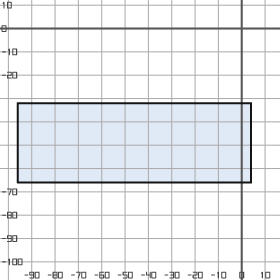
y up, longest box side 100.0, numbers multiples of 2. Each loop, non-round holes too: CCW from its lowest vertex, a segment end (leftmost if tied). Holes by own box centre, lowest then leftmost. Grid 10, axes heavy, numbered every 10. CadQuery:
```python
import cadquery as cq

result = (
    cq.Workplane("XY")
    .moveTo(-96.0, -66.0)
    .lineTo(4.0, -66.0)
    .lineTo(4.0, -32.0)
    .lineTo(-96.0, -32.0)
    .close()
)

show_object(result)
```